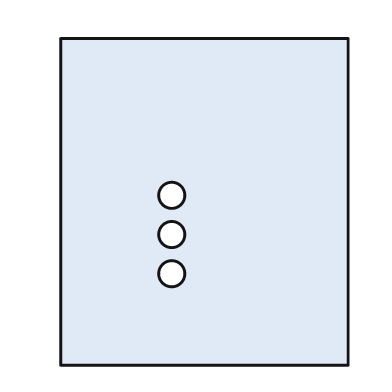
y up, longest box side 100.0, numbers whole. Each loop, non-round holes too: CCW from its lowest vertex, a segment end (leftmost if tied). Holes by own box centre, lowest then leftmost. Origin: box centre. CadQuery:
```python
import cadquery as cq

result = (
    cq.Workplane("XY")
    .moveTo(-44.0, -50.0)
    .lineTo(44.0, -50.0)
    .lineTo(44.0, 50.0)
    .lineTo(-44.0, 50.0)
    .close()
    .moveTo(-10.0, -22.0)
    .circle(4.0)
    .moveTo(-10.0, -10.0)
    .circle(4.0)
    .moveTo(-10.0, 2.0)
    .circle(4.0)
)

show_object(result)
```